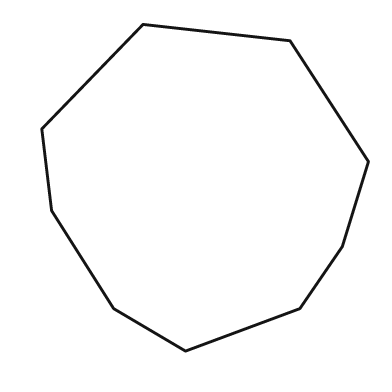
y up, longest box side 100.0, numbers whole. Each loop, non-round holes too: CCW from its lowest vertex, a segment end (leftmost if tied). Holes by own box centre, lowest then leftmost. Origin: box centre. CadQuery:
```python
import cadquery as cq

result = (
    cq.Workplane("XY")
    .moveTo(-6.0, -50.0)
    .lineTo(29.0, -37.0)
    .lineTo(42.0, -18.0)
    .lineTo(50.0, 8.0)
    .lineTo(26.0, 45.0)
    .lineTo(-19.0, 50.0)
    .lineTo(-50.0, 18.0)
    .lineTo(-47.0, -7.0)
    .lineTo(-28.0, -37.0)
    .close()
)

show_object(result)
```